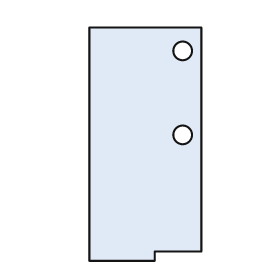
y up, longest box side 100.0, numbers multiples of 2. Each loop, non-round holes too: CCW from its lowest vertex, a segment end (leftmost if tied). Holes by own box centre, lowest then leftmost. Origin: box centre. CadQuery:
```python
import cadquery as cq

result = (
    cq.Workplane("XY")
    .moveTo(-24.0, -50.0)
    .lineTo(4.0, -50.0)
    .lineTo(4.0, -46.0)
    .lineTo(24.0, -46.0)
    .lineTo(24.0, 50.0)
    .lineTo(-24.0, 50.0)
    .close()
    .moveTo(16.0, 4.0)
    .circle(4.0)
    .moveTo(16.0, 40.0)
    .circle(4.0)
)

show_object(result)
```